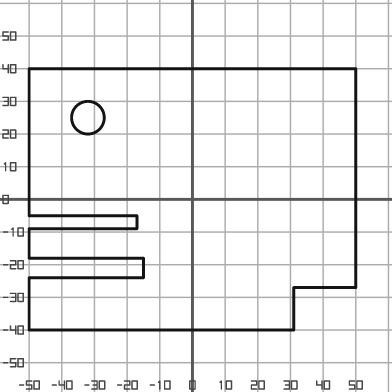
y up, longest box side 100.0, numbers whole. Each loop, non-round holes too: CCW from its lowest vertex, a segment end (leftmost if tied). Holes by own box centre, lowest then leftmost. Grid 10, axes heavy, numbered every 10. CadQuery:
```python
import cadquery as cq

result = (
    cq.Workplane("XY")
    .moveTo(-50.0, -40.0)
    .lineTo(31.0, -40.0)
    .lineTo(31.0, -27.0)
    .lineTo(50.0, -27.0)
    .lineTo(50.0, 40.0)
    .lineTo(-50.0, 40.0)
    .lineTo(-50.0, -5.0)
    .lineTo(-17.0, -5.0)
    .lineTo(-17.0, -9.0)
    .lineTo(-50.0, -9.0)
    .lineTo(-50.0, -18.0)
    .lineTo(-15.0, -18.0)
    .lineTo(-15.0, -24.0)
    .lineTo(-50.0, -24.0)
    .close()
    .moveTo(-32.0, 25.0)
    .circle(5.0)
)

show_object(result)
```